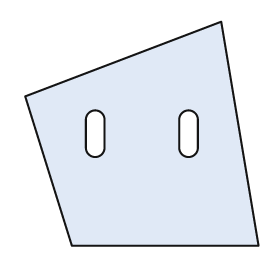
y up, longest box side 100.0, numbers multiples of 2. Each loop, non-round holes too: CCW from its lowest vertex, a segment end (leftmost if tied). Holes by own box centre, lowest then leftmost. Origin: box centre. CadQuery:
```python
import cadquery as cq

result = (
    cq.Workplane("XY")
    .moveTo(-30.0, -48.0)
    .lineTo(50.0, -48.0)
    .lineTo(34.0, 48.0)
    .lineTo(-50.0, 16.0)
    .close()
    .moveTo(-24.0, -6.0)
    .threePointArc((-20.0, -10.0), (-16.0, -6.0))
    .lineTo(-16.0, 6.0)
    .threePointArc((-20.0, 10.0), (-24.0, 6.0))
    .close()
    .moveTo(16.0, -6.0)
    .threePointArc((20.0, -10.0), (24.0, -6.0))
    .lineTo(24.0, 6.0)
    .threePointArc((20.0, 10.0), (16.0, 6.0))
    .close()
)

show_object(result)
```